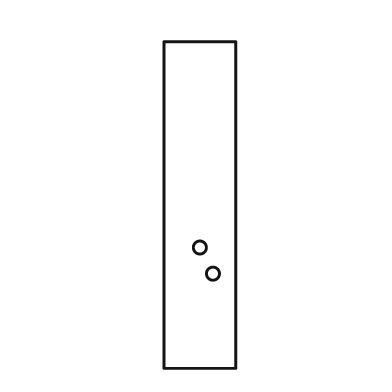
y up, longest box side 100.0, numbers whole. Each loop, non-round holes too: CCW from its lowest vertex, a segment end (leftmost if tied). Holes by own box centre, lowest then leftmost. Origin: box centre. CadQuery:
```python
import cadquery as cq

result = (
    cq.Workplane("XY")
    .moveTo(-11.0, -50.0)
    .lineTo(11.0, -50.0)
    .lineTo(11.0, 50.0)
    .lineTo(-11.0, 50.0)
    .close()
    .moveTo(4.0, -21.0)
    .circle(2.0)
    .moveTo(0.0, -13.0)
    .circle(2.0)
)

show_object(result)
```